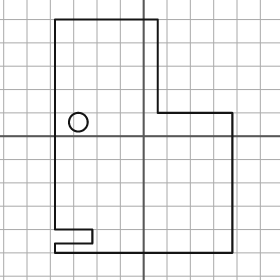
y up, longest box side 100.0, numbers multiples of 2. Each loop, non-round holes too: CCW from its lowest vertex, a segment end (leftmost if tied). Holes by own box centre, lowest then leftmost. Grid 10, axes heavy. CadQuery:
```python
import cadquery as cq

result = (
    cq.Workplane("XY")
    .moveTo(-38.0, -50.0)
    .lineTo(38.0, -50.0)
    .lineTo(38.0, 10.0)
    .lineTo(6.0, 10.0)
    .lineTo(6.0, 50.0)
    .lineTo(-38.0, 50.0)
    .lineTo(-38.0, -40.0)
    .lineTo(-22.0, -40.0)
    .lineTo(-22.0, -46.0)
    .lineTo(-38.0, -46.0)
    .close()
    .moveTo(-28.0, 6.0)
    .circle(4.0)
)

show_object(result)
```